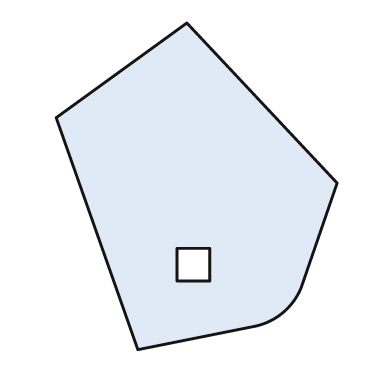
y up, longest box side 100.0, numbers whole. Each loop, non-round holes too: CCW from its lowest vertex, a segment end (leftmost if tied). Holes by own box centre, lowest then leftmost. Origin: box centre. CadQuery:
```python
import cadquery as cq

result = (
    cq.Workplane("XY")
    .moveTo(-18.0, -50.0)
    .lineTo(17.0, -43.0)
    .threePointArc((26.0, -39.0), (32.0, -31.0))
    .lineTo(43.0, 1.0)
    .lineTo(-3.0, 50.0)
    .lineTo(-43.0, 21.0)
    .close()
    .moveTo(-6.0, -29.0)
    .lineTo(4.0, -29.0)
    .lineTo(4.0, -19.0)
    .lineTo(-6.0, -19.0)
    .close()
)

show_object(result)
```